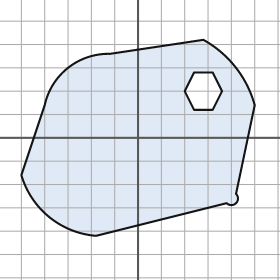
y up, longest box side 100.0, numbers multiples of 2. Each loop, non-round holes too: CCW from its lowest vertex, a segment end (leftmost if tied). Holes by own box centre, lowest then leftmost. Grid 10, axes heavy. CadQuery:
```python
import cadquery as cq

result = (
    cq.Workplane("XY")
    .moveTo(-18.0, -42.0)
    .lineTo(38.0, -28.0)
    .threePointArc((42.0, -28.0), (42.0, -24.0))
    .lineTo(50.0, 14.0)
    .threePointArc((42.0, 30.0), (28.0, 42.0))
    .lineTo(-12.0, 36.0)
    .threePointArc((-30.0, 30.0), (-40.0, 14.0))
    .lineTo(-50.0, -16.0)
    .threePointArc((-38.0, -34.0), (-18.0, -42.0))
    .close()
    .moveTo(24.0, 12.0)
    .lineTo(32.0, 12.0)
    .lineTo(36.0, 20.0)
    .lineTo(32.0, 28.0)
    .lineTo(24.0, 28.0)
    .lineTo(20.0, 20.0)
    .close()
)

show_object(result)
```